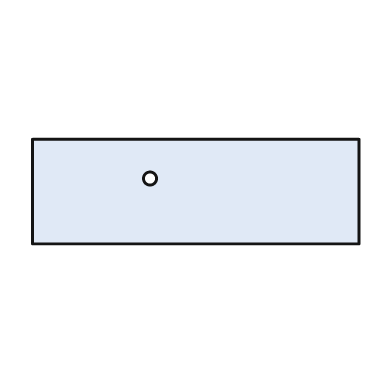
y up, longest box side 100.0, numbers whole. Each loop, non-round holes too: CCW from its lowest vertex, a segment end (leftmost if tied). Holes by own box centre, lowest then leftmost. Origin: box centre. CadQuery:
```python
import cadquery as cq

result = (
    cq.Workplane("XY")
    .moveTo(-50.0, -16.0)
    .lineTo(50.0, -16.0)
    .lineTo(50.0, 16.0)
    .lineTo(-50.0, 16.0)
    .close()
    .moveTo(-14.0, 4.0)
    .circle(2.0)
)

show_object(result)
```